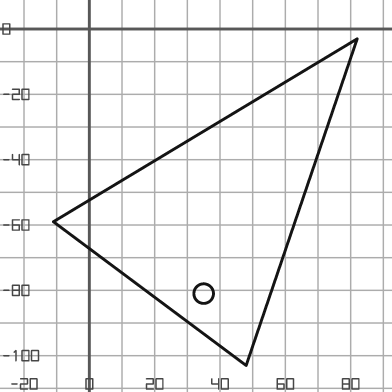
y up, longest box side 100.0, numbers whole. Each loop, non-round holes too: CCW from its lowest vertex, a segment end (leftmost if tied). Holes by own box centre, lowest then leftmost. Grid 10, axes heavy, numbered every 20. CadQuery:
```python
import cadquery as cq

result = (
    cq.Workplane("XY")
    .moveTo(48.0, -103.0)
    .lineTo(82.0, -3.0)
    .lineTo(-11.0, -59.0)
    .close()
    .moveTo(35.0, -81.0)
    .circle(3.0)
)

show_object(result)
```